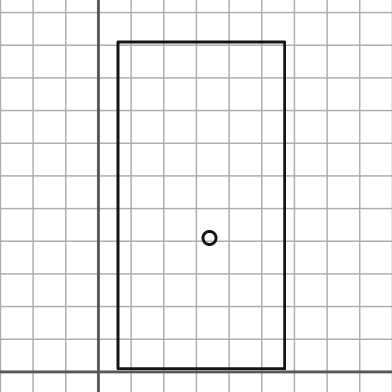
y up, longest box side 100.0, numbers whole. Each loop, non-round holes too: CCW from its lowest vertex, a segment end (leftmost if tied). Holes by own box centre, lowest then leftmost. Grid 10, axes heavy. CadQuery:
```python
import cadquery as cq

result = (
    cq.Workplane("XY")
    .moveTo(6.0, 1.0)
    .lineTo(57.0, 1.0)
    .lineTo(57.0, 101.0)
    .lineTo(6.0, 101.0)
    .close()
    .moveTo(34.0, 41.0)
    .circle(2.0)
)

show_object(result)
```